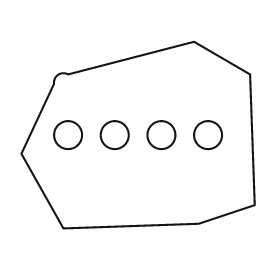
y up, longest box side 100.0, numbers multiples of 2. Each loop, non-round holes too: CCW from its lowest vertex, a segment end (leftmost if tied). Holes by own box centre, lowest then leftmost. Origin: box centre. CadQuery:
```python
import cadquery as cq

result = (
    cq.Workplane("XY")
    .moveTo(-32.0, -40.0)
    .lineTo(26.0, -38.0)
    .lineTo(50.0, -30.0)
    .lineTo(48.0, 26.0)
    .lineTo(24.0, 40.0)
    .lineTo(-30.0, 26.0)
    .threePointArc((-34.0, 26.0), (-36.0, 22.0))
    .lineTo(-50.0, -8.0)
    .close()
    .moveTo(-30.0, 0.0)
    .circle(6.0)
    .moveTo(-10.0, 0.0)
    .circle(6.0)
    .moveTo(10.0, 0.0)
    .circle(6.0)
    .moveTo(30.0, 0.0)
    .circle(6.0)
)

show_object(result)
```